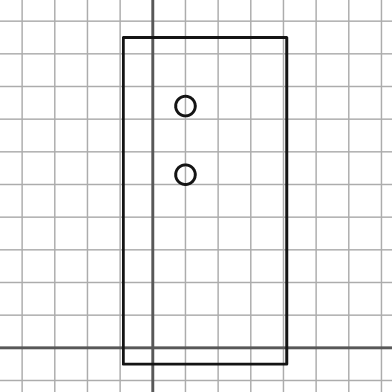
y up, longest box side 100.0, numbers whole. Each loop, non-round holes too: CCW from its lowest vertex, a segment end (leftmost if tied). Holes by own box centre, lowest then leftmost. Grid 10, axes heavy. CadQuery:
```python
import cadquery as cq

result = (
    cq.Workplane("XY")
    .moveTo(-9.0, -5.0)
    .lineTo(41.0, -5.0)
    .lineTo(41.0, 95.0)
    .lineTo(-9.0, 95.0)
    .close()
    .moveTo(10.0, 53.0)
    .circle(3.0)
    .moveTo(10.0, 74.0)
    .circle(3.0)
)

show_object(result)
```